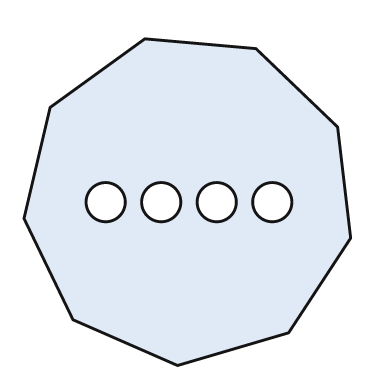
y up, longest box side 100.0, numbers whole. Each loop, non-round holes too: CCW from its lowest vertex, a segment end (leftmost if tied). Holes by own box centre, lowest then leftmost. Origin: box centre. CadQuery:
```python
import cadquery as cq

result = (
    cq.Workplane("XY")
    .moveTo(-3.0, -50.0)
    .lineTo(31.0, -40.0)
    .lineTo(50.0, -11.0)
    .lineTo(46.0, 23.0)
    .lineTo(21.0, 47.0)
    .lineTo(-13.0, 50.0)
    .lineTo(-42.0, 29.0)
    .lineTo(-50.0, -5.0)
    .lineTo(-35.0, -36.0)
    .close()
    .moveTo(-25.0, 0.0)
    .circle(6.0)
    .moveTo(-8.0, 0.0)
    .circle(6.0)
    .moveTo(9.0, 0.0)
    .circle(6.0)
    .moveTo(26.0, 0.0)
    .circle(6.0)
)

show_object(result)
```